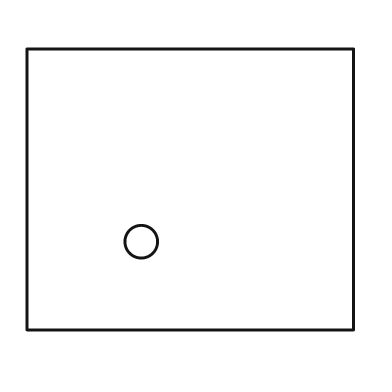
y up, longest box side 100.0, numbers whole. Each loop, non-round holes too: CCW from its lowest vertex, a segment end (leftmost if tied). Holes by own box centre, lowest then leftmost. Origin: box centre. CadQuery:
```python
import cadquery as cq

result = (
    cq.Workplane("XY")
    .moveTo(-50.0, -43.0)
    .lineTo(50.0, -43.0)
    .lineTo(50.0, 43.0)
    .lineTo(-50.0, 43.0)
    .close()
    .moveTo(-15.0, -16.0)
    .circle(5.0)
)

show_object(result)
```